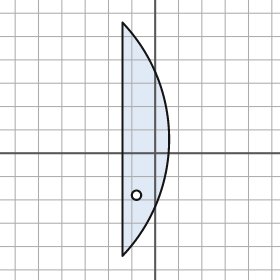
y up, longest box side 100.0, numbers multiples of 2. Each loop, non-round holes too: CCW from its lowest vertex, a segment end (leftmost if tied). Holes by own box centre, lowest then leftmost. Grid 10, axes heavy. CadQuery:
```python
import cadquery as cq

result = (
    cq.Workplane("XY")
    .moveTo(-14.0, -44.0)
    .threePointArc((6.0, 6.0), (-14.0, 56.0))
    .close()
    .moveTo(-8.0, -18.0)
    .circle(2.0)
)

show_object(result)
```